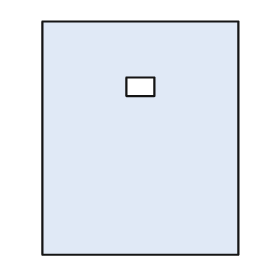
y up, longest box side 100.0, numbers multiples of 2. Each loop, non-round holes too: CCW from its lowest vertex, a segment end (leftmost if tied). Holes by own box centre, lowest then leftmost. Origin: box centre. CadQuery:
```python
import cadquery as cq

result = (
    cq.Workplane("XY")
    .moveTo(-42.0, -50.0)
    .lineTo(42.0, -50.0)
    .lineTo(42.0, 50.0)
    .lineTo(-42.0, 50.0)
    .close()
    .moveTo(-6.0, 18.0)
    .lineTo(6.0, 18.0)
    .lineTo(6.0, 26.0)
    .lineTo(-6.0, 26.0)
    .close()
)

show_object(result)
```